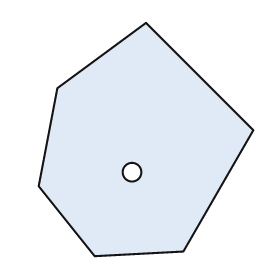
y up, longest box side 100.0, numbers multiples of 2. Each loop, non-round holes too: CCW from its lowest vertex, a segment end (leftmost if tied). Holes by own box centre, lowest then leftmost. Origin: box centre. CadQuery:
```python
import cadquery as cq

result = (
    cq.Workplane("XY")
    .moveTo(-22.0, -50.0)
    .lineTo(16.0, -48.0)
    .lineTo(46.0, 4.0)
    .lineTo(0.0, 50.0)
    .lineTo(-38.0, 22.0)
    .lineTo(-46.0, -20.0)
    .close()
    .moveTo(-6.0, -14.0)
    .circle(4.0)
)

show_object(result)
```